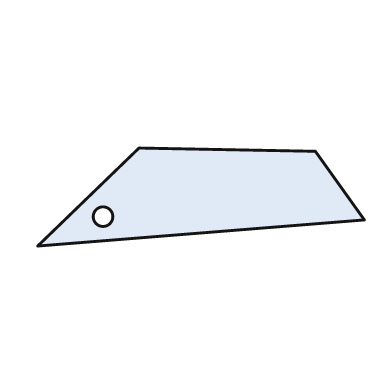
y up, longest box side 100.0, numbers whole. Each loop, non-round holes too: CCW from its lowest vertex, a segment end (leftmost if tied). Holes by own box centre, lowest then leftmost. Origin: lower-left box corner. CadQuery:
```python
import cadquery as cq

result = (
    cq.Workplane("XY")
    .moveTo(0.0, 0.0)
    .lineTo(100.0, 8.0)
    .lineTo(85.0, 29.0)
    .lineTo(31.0, 30.0)
    .close()
    .moveTo(20.0, 9.0)
    .circle(3.0)
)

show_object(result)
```